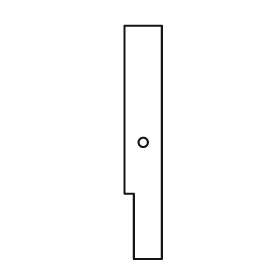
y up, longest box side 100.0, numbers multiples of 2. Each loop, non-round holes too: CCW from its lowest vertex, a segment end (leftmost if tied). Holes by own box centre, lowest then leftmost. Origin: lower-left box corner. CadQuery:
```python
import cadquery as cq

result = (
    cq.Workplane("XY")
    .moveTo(4.0, 0.0)
    .lineTo(16.0, 0.0)
    .lineTo(16.0, 100.0)
    .lineTo(0.0, 100.0)
    .lineTo(0.0, 28.0)
    .lineTo(4.0, 28.0)
    .close()
    .moveTo(8.0, 50.0)
    .circle(2.0)
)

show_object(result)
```